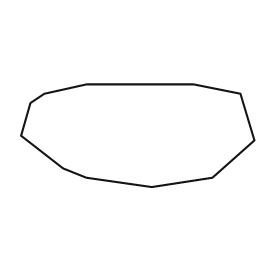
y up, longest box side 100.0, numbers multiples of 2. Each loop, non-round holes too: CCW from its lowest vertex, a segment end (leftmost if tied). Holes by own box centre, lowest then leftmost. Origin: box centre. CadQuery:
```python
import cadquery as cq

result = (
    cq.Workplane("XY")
    .moveTo(6.0, -22.0)
    .lineTo(32.0, -18.0)
    .lineTo(50.0, -2.0)
    .lineTo(44.0, 18.0)
    .lineTo(24.0, 22.0)
    .lineTo(-22.0, 22.0)
    .lineTo(-40.0, 18.0)
    .lineTo(-46.0, 14.0)
    .lineTo(-50.0, 0.0)
    .lineTo(-32.0, -14.0)
    .lineTo(-22.0, -18.0)
    .close()
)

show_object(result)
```